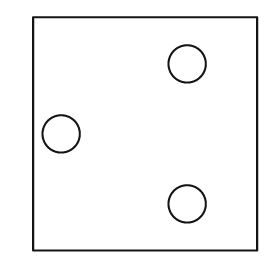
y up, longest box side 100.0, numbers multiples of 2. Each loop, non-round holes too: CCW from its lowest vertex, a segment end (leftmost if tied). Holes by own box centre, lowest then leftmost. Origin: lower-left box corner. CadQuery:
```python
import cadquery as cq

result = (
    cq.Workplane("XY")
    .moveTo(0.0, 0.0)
    .lineTo(96.0, 0.0)
    .lineTo(96.0, 100.0)
    .lineTo(0.0, 100.0)
    .close()
    .moveTo(66.0, 20.0)
    .circle(8.0)
    .moveTo(12.0, 50.0)
    .circle(8.0)
    .moveTo(66.0, 80.0)
    .circle(8.0)
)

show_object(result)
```